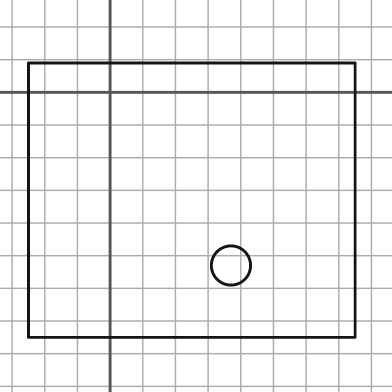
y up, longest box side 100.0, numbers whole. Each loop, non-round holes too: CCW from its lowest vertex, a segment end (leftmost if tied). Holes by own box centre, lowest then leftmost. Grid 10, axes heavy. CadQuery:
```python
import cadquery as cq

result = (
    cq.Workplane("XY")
    .moveTo(-25.0, -75.0)
    .lineTo(75.0, -75.0)
    .lineTo(75.0, 9.0)
    .lineTo(-25.0, 9.0)
    .close()
    .moveTo(37.0, -53.0)
    .circle(6.0)
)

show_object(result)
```